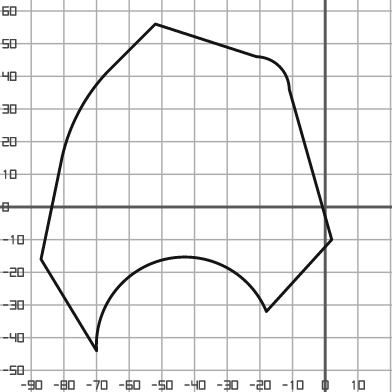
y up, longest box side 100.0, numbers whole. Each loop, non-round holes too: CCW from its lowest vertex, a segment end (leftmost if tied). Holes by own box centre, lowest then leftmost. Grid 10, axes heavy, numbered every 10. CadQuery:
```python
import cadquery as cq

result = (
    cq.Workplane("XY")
    .moveTo(-70.0, -44.0)
    .threePointArc((-49.0, -16.0), (-18.0, -32.0))
    .lineTo(2.0, -10.0)
    .lineTo(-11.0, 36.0)
    .threePointArc((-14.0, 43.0), (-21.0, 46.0))
    .lineTo(-52.0, 56.0)
    .lineTo(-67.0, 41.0)
    .threePointArc((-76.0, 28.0), (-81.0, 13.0))
    .lineTo(-87.0, -16.0)
    .close()
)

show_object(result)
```